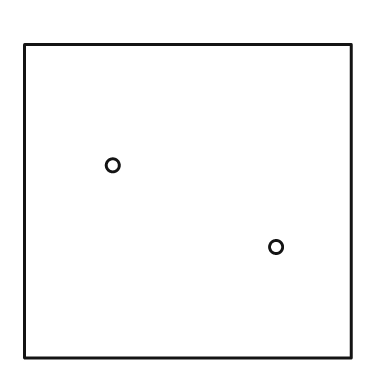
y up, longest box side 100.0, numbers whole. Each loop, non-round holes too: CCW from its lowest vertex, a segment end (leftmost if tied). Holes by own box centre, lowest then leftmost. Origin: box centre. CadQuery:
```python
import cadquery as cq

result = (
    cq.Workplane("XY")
    .moveTo(-50.0, -48.0)
    .lineTo(50.0, -48.0)
    .lineTo(50.0, 48.0)
    .lineTo(-50.0, 48.0)
    .close()
    .moveTo(27.0, -14.0)
    .circle(2.0)
    .moveTo(-23.0, 11.0)
    .circle(2.0)
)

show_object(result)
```